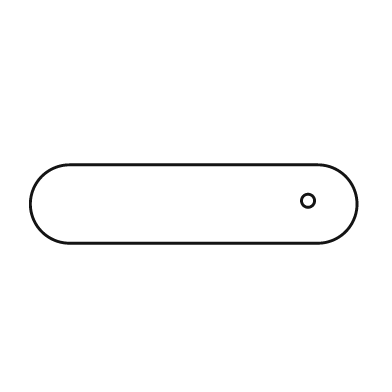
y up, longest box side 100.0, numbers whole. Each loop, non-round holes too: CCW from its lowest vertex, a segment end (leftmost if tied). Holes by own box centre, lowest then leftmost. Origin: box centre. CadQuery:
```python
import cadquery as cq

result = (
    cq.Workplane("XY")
    .moveTo(-38.0, -12.0)
    .lineTo(38.0, -12.0)
    .threePointArc((50.0, 0.0), (38.0, 12.0))
    .lineTo(-38.0, 12.0)
    .threePointArc((-50.0, 0.0), (-38.0, -12.0))
    .close()
    .moveTo(35.0, 1.0)
    .circle(2.0)
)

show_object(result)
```